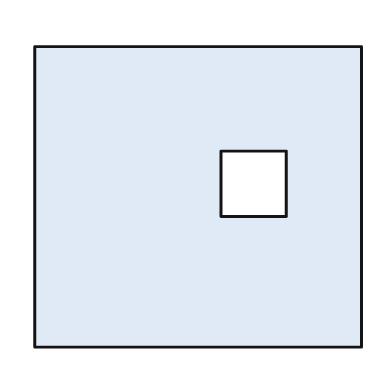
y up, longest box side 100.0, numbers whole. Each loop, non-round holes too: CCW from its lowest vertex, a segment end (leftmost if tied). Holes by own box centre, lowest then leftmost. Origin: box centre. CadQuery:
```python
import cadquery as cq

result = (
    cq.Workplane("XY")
    .moveTo(-50.0, -46.0)
    .lineTo(50.0, -46.0)
    .lineTo(50.0, 46.0)
    .lineTo(-50.0, 46.0)
    .close()
    .moveTo(7.0, -6.0)
    .lineTo(27.0, -6.0)
    .lineTo(27.0, 14.0)
    .lineTo(7.0, 14.0)
    .close()
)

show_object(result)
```